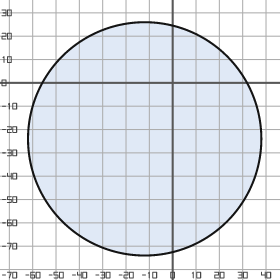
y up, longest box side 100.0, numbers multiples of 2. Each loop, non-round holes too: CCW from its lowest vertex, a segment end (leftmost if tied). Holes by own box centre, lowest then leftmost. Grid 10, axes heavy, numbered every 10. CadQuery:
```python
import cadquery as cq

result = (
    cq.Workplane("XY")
    .moveTo(-12.0, -24.0)
    .circle(50.0)
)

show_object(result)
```